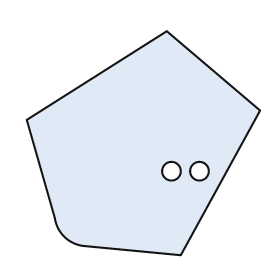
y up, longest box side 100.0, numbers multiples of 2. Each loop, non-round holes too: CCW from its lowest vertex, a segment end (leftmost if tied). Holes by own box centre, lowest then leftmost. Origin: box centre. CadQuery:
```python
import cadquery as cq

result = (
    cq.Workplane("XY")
    .moveTo(16.0, -48.0)
    .lineTo(50.0, 14.0)
    .lineTo(10.0, 48.0)
    .lineTo(-50.0, 10.0)
    .lineTo(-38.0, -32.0)
    .threePointArc((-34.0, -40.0), (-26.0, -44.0))
    .close()
    .moveTo(12.0, -12.0)
    .circle(4.0)
    .moveTo(24.0, -12.0)
    .circle(4.0)
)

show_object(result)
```